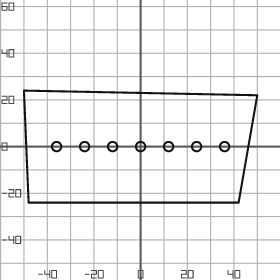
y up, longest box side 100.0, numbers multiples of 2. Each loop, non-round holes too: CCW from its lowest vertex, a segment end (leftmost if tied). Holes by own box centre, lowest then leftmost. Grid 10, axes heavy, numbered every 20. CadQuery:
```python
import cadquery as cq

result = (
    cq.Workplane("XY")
    .moveTo(-48.0, -24.0)
    .lineTo(42.0, -24.0)
    .lineTo(50.0, 22.0)
    .lineTo(-50.0, 24.0)
    .close()
    .moveTo(-36.0, 0.0)
    .circle(2.0)
    .moveTo(-24.0, 0.0)
    .circle(2.0)
    .moveTo(-12.0, 0.0)
    .circle(2.0)
    .moveTo(0.0, 0.0)
    .circle(2.0)
    .moveTo(12.0, 0.0)
    .circle(2.0)
    .moveTo(24.0, 0.0)
    .circle(2.0)
    .moveTo(36.0, 0.0)
    .circle(2.0)
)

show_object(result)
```